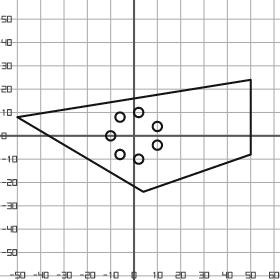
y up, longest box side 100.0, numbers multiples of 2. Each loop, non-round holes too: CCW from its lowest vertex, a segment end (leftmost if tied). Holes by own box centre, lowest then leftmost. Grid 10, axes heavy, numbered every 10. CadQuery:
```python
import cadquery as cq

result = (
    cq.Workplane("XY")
    .moveTo(4.0, -24.0)
    .lineTo(50.0, -8.0)
    .lineTo(50.0, 24.0)
    .lineTo(-50.0, 8.0)
    .close()
    .moveTo(2.0, -10.0)
    .circle(2.0)
    .moveTo(-6.0, -8.0)
    .circle(2.0)
    .moveTo(10.0, -4.0)
    .circle(2.0)
    .moveTo(-10.0, 0.0)
    .circle(2.0)
    .moveTo(10.0, 4.0)
    .circle(2.0)
    .moveTo(-6.0, 8.0)
    .circle(2.0)
    .moveTo(2.0, 10.0)
    .circle(2.0)
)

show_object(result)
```